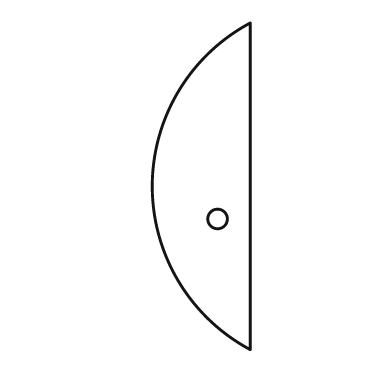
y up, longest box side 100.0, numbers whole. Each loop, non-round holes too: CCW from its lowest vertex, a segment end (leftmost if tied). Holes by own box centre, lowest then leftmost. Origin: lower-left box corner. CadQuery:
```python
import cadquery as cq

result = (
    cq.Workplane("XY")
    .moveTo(30.0, 0.0)
    .lineTo(30.0, 100.0)
    .threePointArc((0.0, 50.0), (30.0, 0.0))
    .close()
    .moveTo(20.0, 40.0)
    .circle(3.0)
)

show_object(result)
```